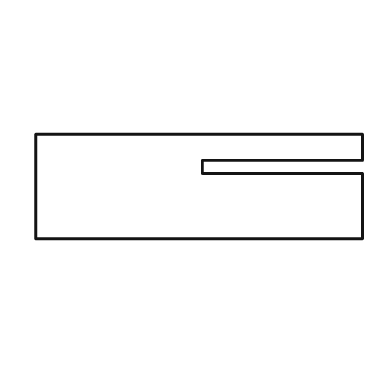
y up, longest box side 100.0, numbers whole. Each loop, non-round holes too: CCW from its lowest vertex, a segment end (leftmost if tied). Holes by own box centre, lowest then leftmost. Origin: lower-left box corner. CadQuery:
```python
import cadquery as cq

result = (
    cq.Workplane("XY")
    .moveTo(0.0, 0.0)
    .lineTo(100.0, 0.0)
    .lineTo(100.0, 20.0)
    .lineTo(51.0, 20.0)
    .lineTo(51.0, 24.0)
    .lineTo(100.0, 24.0)
    .lineTo(100.0, 32.0)
    .lineTo(0.0, 32.0)
    .close()
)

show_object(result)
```